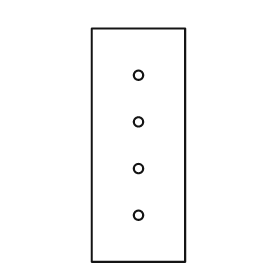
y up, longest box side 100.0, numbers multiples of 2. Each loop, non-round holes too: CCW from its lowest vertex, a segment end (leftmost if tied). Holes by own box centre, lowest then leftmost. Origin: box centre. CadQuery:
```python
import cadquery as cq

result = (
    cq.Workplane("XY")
    .moveTo(-20.0, -50.0)
    .lineTo(20.0, -50.0)
    .lineTo(20.0, 50.0)
    .lineTo(-20.0, 50.0)
    .close()
    .moveTo(0.0, -30.0)
    .circle(2.0)
    .moveTo(0.0, -10.0)
    .circle(2.0)
    .moveTo(0.0, 10.0)
    .circle(2.0)
    .moveTo(0.0, 30.0)
    .circle(2.0)
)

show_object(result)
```